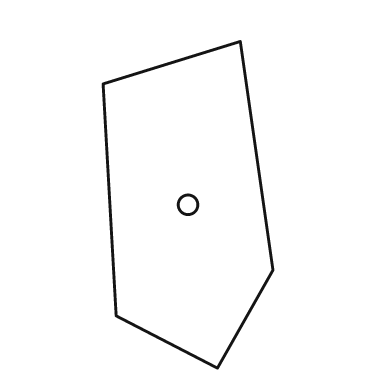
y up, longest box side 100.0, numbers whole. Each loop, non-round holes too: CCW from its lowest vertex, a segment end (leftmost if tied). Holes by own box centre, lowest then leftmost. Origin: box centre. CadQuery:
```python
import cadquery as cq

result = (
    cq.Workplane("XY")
    .moveTo(9.0, -50.0)
    .lineTo(26.0, -20.0)
    .lineTo(16.0, 50.0)
    .lineTo(-26.0, 37.0)
    .lineTo(-22.0, -34.0)
    .close()
    .moveTo(0.0, 0.0)
    .circle(3.0)
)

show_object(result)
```